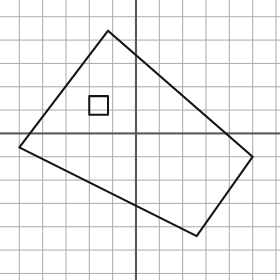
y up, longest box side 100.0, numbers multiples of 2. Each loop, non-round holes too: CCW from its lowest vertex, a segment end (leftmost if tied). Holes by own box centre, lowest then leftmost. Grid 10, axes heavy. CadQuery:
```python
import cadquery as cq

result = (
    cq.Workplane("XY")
    .moveTo(26.0, -44.0)
    .lineTo(50.0, -10.0)
    .lineTo(-12.0, 44.0)
    .lineTo(-50.0, -6.0)
    .close()
    .moveTo(-20.0, 8.0)
    .lineTo(-12.0, 8.0)
    .lineTo(-12.0, 16.0)
    .lineTo(-20.0, 16.0)
    .close()
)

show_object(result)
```